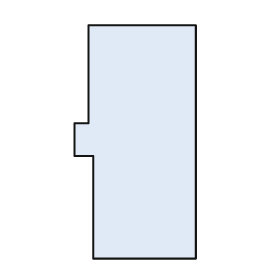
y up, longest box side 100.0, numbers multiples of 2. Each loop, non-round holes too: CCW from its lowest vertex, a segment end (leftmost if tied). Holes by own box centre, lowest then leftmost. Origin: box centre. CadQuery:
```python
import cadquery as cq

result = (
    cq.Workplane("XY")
    .moveTo(-18.0, -50.0)
    .lineTo(26.0, -50.0)
    .lineTo(26.0, 50.0)
    .lineTo(-20.0, 50.0)
    .lineTo(-20.0, 8.0)
    .lineTo(-26.0, 8.0)
    .lineTo(-26.0, -6.0)
    .lineTo(-18.0, -6.0)
    .close()
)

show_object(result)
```